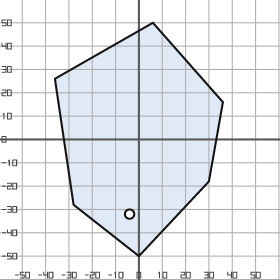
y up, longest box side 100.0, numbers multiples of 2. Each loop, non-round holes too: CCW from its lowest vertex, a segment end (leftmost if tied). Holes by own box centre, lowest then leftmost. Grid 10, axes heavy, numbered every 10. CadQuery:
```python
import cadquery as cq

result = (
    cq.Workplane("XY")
    .moveTo(0.0, -50.0)
    .lineTo(30.0, -18.0)
    .lineTo(36.0, 16.0)
    .lineTo(6.0, 50.0)
    .lineTo(-36.0, 26.0)
    .lineTo(-28.0, -28.0)
    .close()
    .moveTo(-4.0, -32.0)
    .circle(2.0)
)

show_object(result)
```